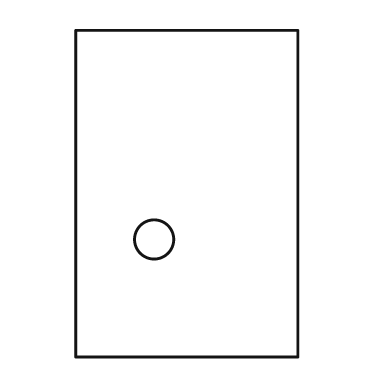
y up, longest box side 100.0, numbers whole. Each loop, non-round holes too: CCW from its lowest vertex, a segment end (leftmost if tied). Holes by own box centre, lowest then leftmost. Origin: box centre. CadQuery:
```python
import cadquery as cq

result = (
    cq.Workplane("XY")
    .moveTo(-34.0, -50.0)
    .lineTo(34.0, -50.0)
    .lineTo(34.0, 50.0)
    .lineTo(-34.0, 50.0)
    .close()
    .moveTo(-10.0, -14.0)
    .circle(6.0)
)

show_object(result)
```